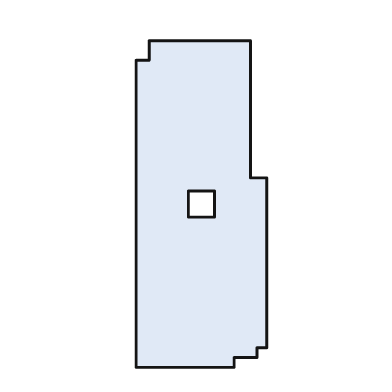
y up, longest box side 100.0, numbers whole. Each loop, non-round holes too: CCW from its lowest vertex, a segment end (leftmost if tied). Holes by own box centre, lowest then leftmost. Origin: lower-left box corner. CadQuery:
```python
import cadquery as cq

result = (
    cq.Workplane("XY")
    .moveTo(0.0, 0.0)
    .lineTo(30.0, 0.0)
    .lineTo(30.0, 3.0)
    .lineTo(37.0, 3.0)
    .lineTo(37.0, 6.0)
    .lineTo(40.0, 6.0)
    .lineTo(40.0, 58.0)
    .lineTo(35.0, 58.0)
    .lineTo(35.0, 100.0)
    .lineTo(4.0, 100.0)
    .lineTo(4.0, 94.0)
    .lineTo(0.0, 94.0)
    .close()
    .moveTo(16.0, 46.0)
    .lineTo(24.0, 46.0)
    .lineTo(24.0, 54.0)
    .lineTo(16.0, 54.0)
    .close()
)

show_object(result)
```